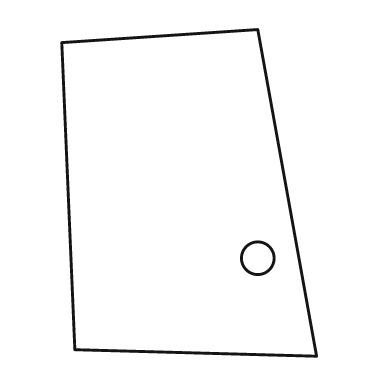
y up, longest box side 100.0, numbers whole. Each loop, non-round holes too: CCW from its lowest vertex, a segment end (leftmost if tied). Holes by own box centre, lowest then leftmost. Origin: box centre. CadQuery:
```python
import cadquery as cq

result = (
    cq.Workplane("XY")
    .moveTo(39.0, -50.0)
    .lineTo(21.0, 50.0)
    .lineTo(-39.0, 46.0)
    .lineTo(-35.0, -48.0)
    .close()
    .moveTo(21.0, -20.0)
    .circle(5.0)
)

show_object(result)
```